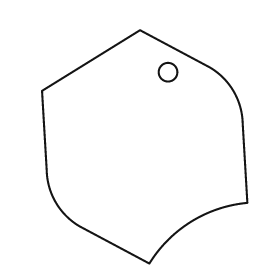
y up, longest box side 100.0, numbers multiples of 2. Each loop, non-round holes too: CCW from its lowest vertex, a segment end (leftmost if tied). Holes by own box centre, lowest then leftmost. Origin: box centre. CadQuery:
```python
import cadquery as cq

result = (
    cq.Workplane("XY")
    .moveTo(2.0, -50.0)
    .threePointArc((20.0, -32.0), (44.0, -24.0))
    .lineTo(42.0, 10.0)
    .threePointArc((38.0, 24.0), (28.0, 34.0))
    .lineTo(-2.0, 50.0)
    .lineTo(-44.0, 24.0)
    .lineTo(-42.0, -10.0)
    .threePointArc((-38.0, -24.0), (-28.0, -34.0))
    .close()
    .moveTo(10.0, 32.0)
    .circle(4.0)
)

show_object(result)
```